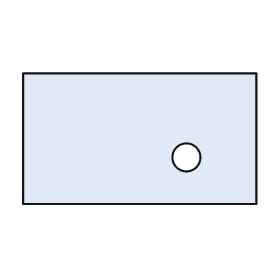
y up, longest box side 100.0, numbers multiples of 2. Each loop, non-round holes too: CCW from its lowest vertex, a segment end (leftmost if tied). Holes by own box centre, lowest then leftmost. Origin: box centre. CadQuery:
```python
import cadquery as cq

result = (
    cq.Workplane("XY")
    .moveTo(-50.0, -28.0)
    .lineTo(50.0, -28.0)
    .lineTo(50.0, 28.0)
    .lineTo(-50.0, 28.0)
    .close()
    .moveTo(20.0, -8.0)
    .circle(6.0)
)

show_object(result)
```